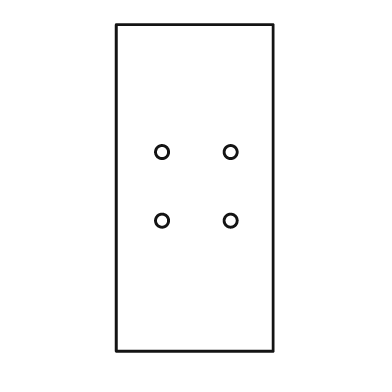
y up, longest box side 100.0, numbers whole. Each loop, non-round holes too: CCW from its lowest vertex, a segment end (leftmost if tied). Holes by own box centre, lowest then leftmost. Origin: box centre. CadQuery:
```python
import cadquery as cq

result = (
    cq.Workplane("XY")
    .moveTo(-24.0, -50.0)
    .lineTo(24.0, -50.0)
    .lineTo(24.0, 50.0)
    .lineTo(-24.0, 50.0)
    .close()
    .moveTo(-10.0, -10.0)
    .circle(2.0)
    .moveTo(11.0, -10.0)
    .circle(2.0)
    .moveTo(-10.0, 11.0)
    .circle(2.0)
    .moveTo(11.0, 11.0)
    .circle(2.0)
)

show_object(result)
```